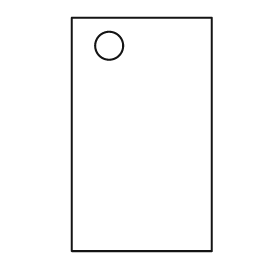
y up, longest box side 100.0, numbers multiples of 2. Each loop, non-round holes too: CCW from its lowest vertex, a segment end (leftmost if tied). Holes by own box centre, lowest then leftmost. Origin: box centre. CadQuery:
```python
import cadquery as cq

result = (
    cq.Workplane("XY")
    .moveTo(-30.0, -50.0)
    .lineTo(30.0, -50.0)
    .lineTo(30.0, 50.0)
    .lineTo(-30.0, 50.0)
    .close()
    .moveTo(-14.0, 38.0)
    .circle(6.0)
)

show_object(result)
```